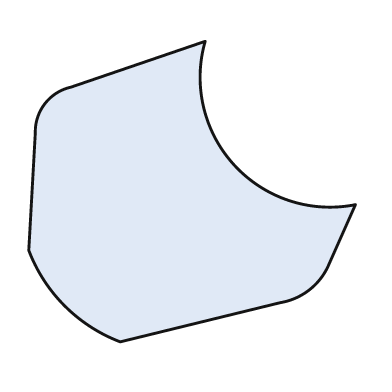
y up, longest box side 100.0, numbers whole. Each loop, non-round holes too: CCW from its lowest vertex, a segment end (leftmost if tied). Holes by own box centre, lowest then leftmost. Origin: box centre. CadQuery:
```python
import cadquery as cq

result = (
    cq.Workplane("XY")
    .moveTo(-22.0, -46.0)
    .lineTo(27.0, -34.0)
    .threePointArc((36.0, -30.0), (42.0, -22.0))
    .lineTo(50.0, -4.0)
    .threePointArc((13.0, 8.0), (4.0, 46.0))
    .lineTo(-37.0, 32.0)
    .threePointArc((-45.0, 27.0), (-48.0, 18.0))
    .lineTo(-50.0, -18.0)
    .threePointArc((-39.0, -35.0), (-22.0, -46.0))
    .close()
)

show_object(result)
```